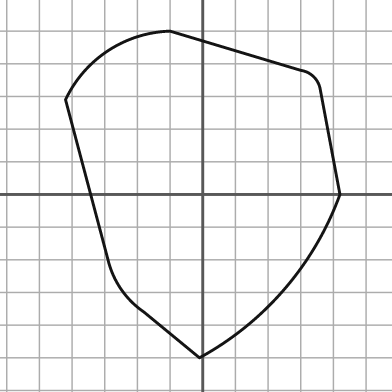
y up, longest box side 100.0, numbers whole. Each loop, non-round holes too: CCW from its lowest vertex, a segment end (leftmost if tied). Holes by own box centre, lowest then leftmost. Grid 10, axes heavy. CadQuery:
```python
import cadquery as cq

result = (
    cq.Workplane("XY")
    .moveTo(-1.0, -50.0)
    .threePointArc((25.0, -29.0), (42.0, 0.0))
    .lineTo(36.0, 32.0)
    .threePointArc((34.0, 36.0), (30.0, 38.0))
    .lineTo(-10.0, 50.0)
    .threePointArc((-29.0, 44.0), (-42.0, 29.0))
    .lineTo(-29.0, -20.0)
    .threePointArc((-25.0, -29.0), (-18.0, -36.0))
    .close()
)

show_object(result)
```